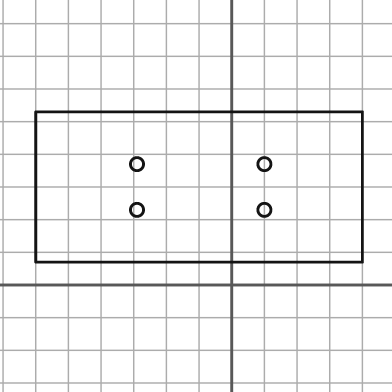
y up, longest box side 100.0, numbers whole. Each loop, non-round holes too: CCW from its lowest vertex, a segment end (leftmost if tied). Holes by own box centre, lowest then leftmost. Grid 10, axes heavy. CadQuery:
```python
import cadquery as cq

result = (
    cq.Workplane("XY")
    .moveTo(-60.0, 7.0)
    .lineTo(40.0, 7.0)
    .lineTo(40.0, 53.0)
    .lineTo(-60.0, 53.0)
    .close()
    .moveTo(-29.0, 23.0)
    .circle(2.0)
    .moveTo(10.0, 23.0)
    .circle(2.0)
    .moveTo(-29.0, 37.0)
    .circle(2.0)
    .moveTo(10.0, 37.0)
    .circle(2.0)
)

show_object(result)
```